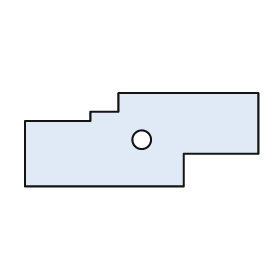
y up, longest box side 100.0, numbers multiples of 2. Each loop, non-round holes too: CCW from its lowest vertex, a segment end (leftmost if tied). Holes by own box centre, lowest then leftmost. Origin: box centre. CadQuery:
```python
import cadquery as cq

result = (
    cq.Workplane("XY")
    .moveTo(-50.0, -20.0)
    .lineTo(18.0, -20.0)
    .lineTo(18.0, -6.0)
    .lineTo(50.0, -6.0)
    .lineTo(50.0, 20.0)
    .lineTo(-10.0, 20.0)
    .lineTo(-10.0, 12.0)
    .lineTo(-22.0, 12.0)
    .lineTo(-22.0, 8.0)
    .lineTo(-50.0, 8.0)
    .close()
    .moveTo(0.0, 0.0)
    .circle(4.0)
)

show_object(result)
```